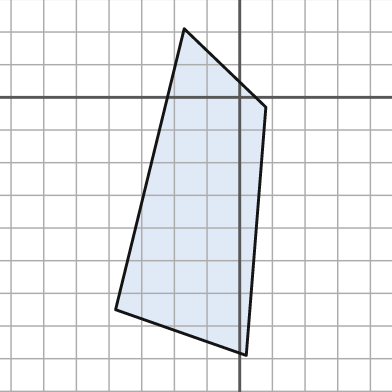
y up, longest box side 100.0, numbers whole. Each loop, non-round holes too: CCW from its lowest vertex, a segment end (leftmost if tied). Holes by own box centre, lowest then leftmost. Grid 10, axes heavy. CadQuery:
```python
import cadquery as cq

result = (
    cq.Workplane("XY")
    .moveTo(2.0, -79.0)
    .lineTo(8.0, -3.0)
    .lineTo(-17.0, 21.0)
    .lineTo(-38.0, -65.0)
    .close()
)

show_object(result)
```